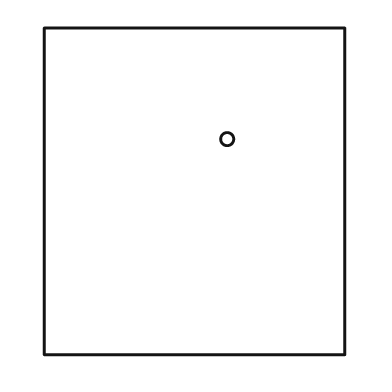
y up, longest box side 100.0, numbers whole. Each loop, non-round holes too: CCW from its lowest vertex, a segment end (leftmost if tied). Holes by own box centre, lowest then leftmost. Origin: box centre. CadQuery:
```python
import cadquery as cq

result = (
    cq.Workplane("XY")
    .moveTo(-46.0, -50.0)
    .lineTo(46.0, -50.0)
    .lineTo(46.0, 50.0)
    .lineTo(-46.0, 50.0)
    .close()
    .moveTo(10.0, 16.0)
    .circle(2.0)
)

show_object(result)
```